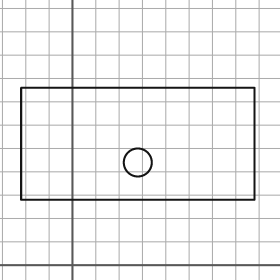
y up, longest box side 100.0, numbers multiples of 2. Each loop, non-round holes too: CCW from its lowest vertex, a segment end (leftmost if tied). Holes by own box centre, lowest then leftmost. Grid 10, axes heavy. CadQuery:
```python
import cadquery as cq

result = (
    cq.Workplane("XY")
    .moveTo(-22.0, 28.0)
    .lineTo(78.0, 28.0)
    .lineTo(78.0, 76.0)
    .lineTo(-22.0, 76.0)
    .close()
    .moveTo(28.0, 44.0)
    .circle(6.0)
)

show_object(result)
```